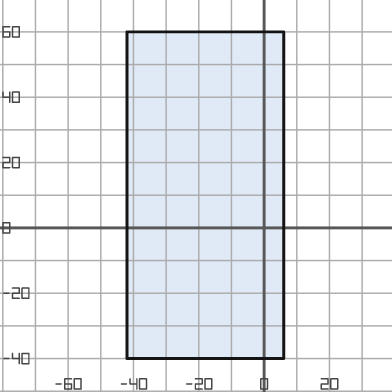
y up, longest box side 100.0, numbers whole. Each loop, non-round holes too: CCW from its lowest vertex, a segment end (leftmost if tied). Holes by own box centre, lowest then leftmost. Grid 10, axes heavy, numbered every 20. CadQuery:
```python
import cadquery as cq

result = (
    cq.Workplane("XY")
    .moveTo(-42.0, -40.0)
    .lineTo(6.0, -40.0)
    .lineTo(6.0, 60.0)
    .lineTo(-42.0, 60.0)
    .close()
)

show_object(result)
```